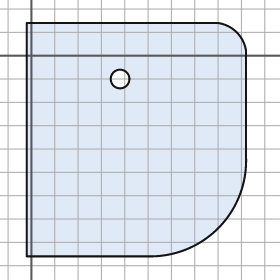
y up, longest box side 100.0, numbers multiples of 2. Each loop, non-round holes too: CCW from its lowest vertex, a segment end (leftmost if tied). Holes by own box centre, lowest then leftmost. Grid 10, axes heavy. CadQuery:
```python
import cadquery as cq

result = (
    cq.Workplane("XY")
    .moveTo(-2.0, -86.0)
    .lineTo(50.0, -86.0)
    .threePointArc((80.0, -74.0), (92.0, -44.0))
    .lineTo(92.0, 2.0)
    .threePointArc((88.0, 10.0), (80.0, 14.0))
    .lineTo(-2.0, 14.0)
    .close()
    .moveTo(38.0, -10.0)
    .circle(4.0)
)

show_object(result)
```